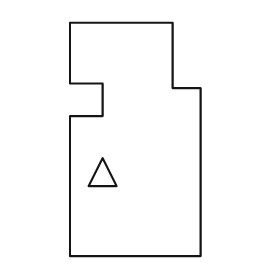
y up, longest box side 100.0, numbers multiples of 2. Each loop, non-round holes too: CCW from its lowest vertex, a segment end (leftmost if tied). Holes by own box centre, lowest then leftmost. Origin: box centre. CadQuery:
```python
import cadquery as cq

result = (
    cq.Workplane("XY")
    .moveTo(-28.0, -50.0)
    .lineTo(28.0, -50.0)
    .lineTo(28.0, 22.0)
    .lineTo(16.0, 22.0)
    .lineTo(16.0, 50.0)
    .lineTo(-28.0, 50.0)
    .lineTo(-28.0, 24.0)
    .lineTo(-14.0, 24.0)
    .lineTo(-14.0, 10.0)
    .lineTo(-28.0, 10.0)
    .close()
    .moveTo(-20.0, -20.0)
    .lineTo(-8.0, -20.0)
    .lineTo(-14.0, -8.0)
    .close()
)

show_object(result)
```